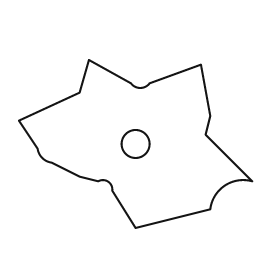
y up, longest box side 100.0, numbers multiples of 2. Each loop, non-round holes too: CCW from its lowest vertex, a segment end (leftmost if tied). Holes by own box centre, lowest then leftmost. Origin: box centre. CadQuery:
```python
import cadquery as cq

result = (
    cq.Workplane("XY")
    .moveTo(0.0, -36.0)
    .lineTo(32.0, -28.0)
    .threePointArc((38.0, -18.0), (50.0, -16.0))
    .lineTo(30.0, 4.0)
    .lineTo(32.0, 12.0)
    .lineTo(28.0, 34.0)
    .lineTo(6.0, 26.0)
    .threePointArc((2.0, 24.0), (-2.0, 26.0))
    .lineTo(-20.0, 36.0)
    .lineTo(-24.0, 22.0)
    .lineTo(-50.0, 10.0)
    .lineTo(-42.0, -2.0)
    .threePointArc((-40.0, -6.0), (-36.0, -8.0))
    .lineTo(-24.0, -14.0)
    .lineTo(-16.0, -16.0)
    .threePointArc((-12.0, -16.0), (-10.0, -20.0))
    .close()
    .moveTo(0.0, 0.0)
    .circle(6.0)
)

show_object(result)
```